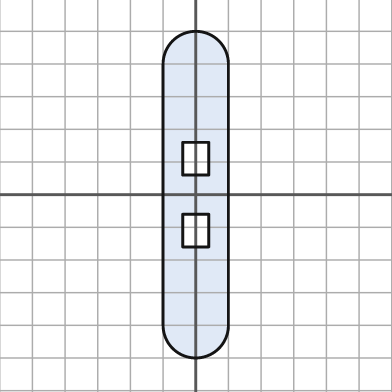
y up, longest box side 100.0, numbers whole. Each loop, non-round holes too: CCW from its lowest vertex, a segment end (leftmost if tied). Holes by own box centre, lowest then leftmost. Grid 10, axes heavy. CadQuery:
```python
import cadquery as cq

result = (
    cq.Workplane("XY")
    .moveTo(-10.0, -40.0)
    .threePointArc((0.0, -50.0), (10.0, -40.0))
    .lineTo(10.0, 40.0)
    .threePointArc((0.0, 50.0), (-10.0, 40.0))
    .close()
    .moveTo(-4.0, -16.0)
    .lineTo(4.0, -16.0)
    .lineTo(4.0, -6.0)
    .lineTo(-4.0, -6.0)
    .close()
    .moveTo(-4.0, 6.0)
    .lineTo(4.0, 6.0)
    .lineTo(4.0, 16.0)
    .lineTo(-4.0, 16.0)
    .close()
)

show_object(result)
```